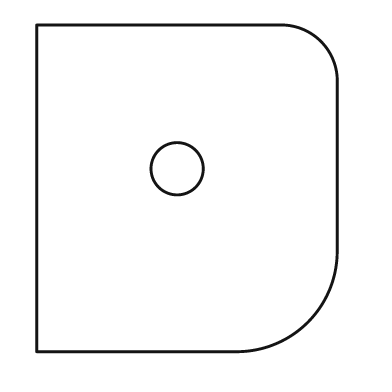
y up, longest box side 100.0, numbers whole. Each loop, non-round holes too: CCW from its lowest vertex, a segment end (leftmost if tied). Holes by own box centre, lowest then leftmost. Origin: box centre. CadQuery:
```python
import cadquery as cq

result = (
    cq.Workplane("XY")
    .moveTo(-46.0, -50.0)
    .lineTo(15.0, -50.0)
    .threePointArc((37.0, -41.0), (46.0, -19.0))
    .lineTo(46.0, 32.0)
    .threePointArc((41.0, 45.0), (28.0, 50.0))
    .lineTo(-46.0, 50.0)
    .close()
    .moveTo(-3.0, 6.0)
    .circle(8.0)
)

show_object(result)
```